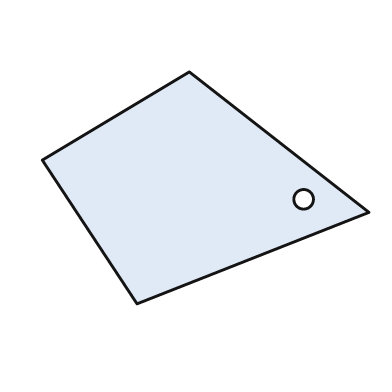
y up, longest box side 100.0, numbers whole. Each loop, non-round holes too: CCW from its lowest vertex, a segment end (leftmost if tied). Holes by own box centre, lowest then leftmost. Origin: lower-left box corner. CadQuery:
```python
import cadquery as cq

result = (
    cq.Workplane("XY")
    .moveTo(29.0, 0.0)
    .lineTo(100.0, 28.0)
    .lineTo(45.0, 71.0)
    .lineTo(0.0, 44.0)
    .close()
    .moveTo(80.0, 32.0)
    .circle(3.0)
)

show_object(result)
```